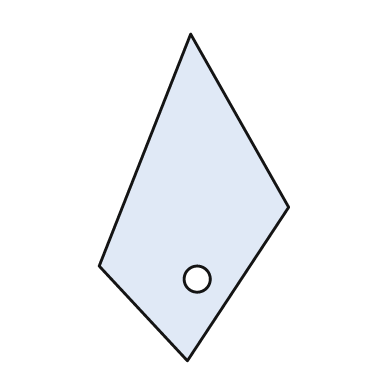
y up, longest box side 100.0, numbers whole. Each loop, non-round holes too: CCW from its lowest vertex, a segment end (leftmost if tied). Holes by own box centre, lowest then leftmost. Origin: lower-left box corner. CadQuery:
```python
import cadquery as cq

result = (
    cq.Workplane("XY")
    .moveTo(27.0, 0.0)
    .lineTo(58.0, 47.0)
    .lineTo(28.0, 100.0)
    .lineTo(0.0, 29.0)
    .close()
    .moveTo(30.0, 25.0)
    .circle(4.0)
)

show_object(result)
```